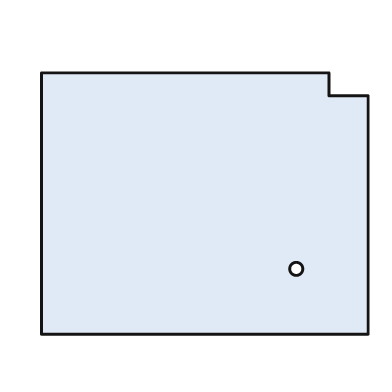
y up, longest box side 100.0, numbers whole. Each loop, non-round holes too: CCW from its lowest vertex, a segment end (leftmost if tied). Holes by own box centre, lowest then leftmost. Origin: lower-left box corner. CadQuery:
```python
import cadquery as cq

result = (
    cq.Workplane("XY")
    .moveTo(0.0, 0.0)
    .lineTo(100.0, 0.0)
    .lineTo(100.0, 73.0)
    .lineTo(88.0, 73.0)
    .lineTo(88.0, 80.0)
    .lineTo(0.0, 80.0)
    .close()
    .moveTo(78.0, 20.0)
    .circle(2.0)
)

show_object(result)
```